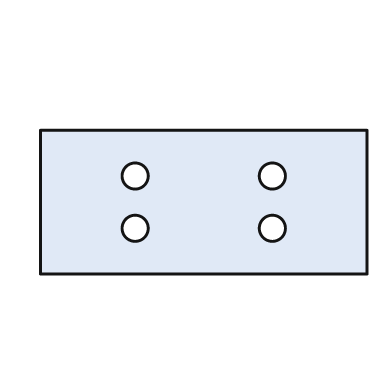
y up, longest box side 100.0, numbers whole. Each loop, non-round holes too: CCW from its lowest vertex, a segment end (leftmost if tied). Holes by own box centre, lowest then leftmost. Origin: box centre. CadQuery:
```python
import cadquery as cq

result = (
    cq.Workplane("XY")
    .moveTo(-50.0, -22.0)
    .lineTo(50.0, -22.0)
    .lineTo(50.0, 22.0)
    .lineTo(-50.0, 22.0)
    .close()
    .moveTo(-21.0, -8.0)
    .circle(4.0)
    .moveTo(21.0, -8.0)
    .circle(4.0)
    .moveTo(-21.0, 8.0)
    .circle(4.0)
    .moveTo(21.0, 8.0)
    .circle(4.0)
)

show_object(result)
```